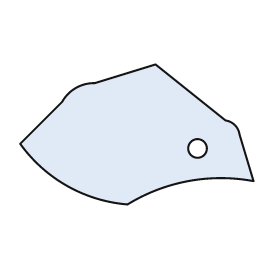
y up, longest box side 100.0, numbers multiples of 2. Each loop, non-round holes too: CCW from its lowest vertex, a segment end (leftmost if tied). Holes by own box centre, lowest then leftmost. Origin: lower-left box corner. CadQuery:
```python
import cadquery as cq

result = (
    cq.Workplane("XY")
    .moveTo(46.0, 0.0)
    .threePointArc((72.0, 10.0), (100.0, 10.0))
    .lineTo(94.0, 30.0)
    .threePointArc((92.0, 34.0), (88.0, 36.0))
    .lineTo(58.0, 60.0)
    .lineTo(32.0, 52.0)
    .threePointArc((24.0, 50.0), (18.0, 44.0))
    .lineTo(0.0, 26.0)
    .threePointArc((20.0, 8.0), (46.0, 0.0))
    .close()
    .moveTo(76.0, 24.0)
    .circle(4.0)
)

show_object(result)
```